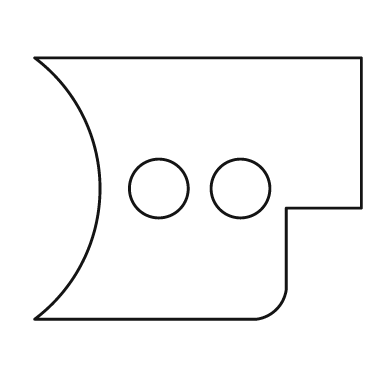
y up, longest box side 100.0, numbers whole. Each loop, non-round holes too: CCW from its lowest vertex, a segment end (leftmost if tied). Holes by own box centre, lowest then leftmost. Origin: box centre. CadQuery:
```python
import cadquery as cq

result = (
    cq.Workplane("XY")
    .moveTo(-50.0, -40.0)
    .lineTo(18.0, -40.0)
    .threePointArc((24.0, -37.0), (27.0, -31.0))
    .lineTo(27.0, -6.0)
    .lineTo(50.0, -6.0)
    .lineTo(50.0, 40.0)
    .lineTo(-50.0, 40.0)
    .threePointArc((-30.0, 0.0), (-50.0, -40.0))
    .close()
    .moveTo(-12.0, 0.0)
    .circle(9.0)
    .moveTo(13.0, 0.0)
    .circle(9.0)
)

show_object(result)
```